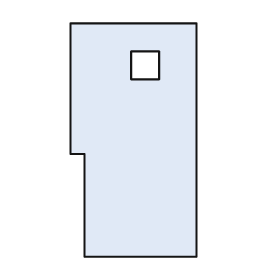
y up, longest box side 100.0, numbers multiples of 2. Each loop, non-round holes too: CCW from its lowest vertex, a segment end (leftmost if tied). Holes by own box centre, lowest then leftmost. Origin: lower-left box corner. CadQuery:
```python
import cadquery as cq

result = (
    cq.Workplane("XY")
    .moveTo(6.0, 0.0)
    .lineTo(54.0, 0.0)
    .lineTo(54.0, 100.0)
    .lineTo(0.0, 100.0)
    .lineTo(0.0, 44.0)
    .lineTo(6.0, 44.0)
    .close()
    .moveTo(26.0, 76.0)
    .lineTo(38.0, 76.0)
    .lineTo(38.0, 88.0)
    .lineTo(26.0, 88.0)
    .close()
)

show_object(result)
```